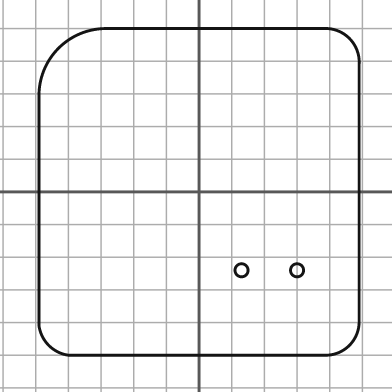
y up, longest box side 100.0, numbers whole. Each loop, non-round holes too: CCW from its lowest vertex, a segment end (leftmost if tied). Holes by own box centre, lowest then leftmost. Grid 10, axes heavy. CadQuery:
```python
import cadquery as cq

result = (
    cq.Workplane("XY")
    .moveTo(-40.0, -50.0)
    .lineTo(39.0, -50.0)
    .threePointArc((46.0, -47.0), (49.0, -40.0))
    .lineTo(49.0, 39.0)
    .threePointArc((46.0, 47.0), (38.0, 50.0))
    .lineTo(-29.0, 50.0)
    .threePointArc((-43.0, 44.0), (-49.0, 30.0))
    .lineTo(-49.0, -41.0)
    .threePointArc((-46.0, -47.0), (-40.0, -50.0))
    .close()
    .moveTo(13.0, -24.0)
    .circle(2.0)
    .moveTo(30.0, -24.0)
    .circle(2.0)
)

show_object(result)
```